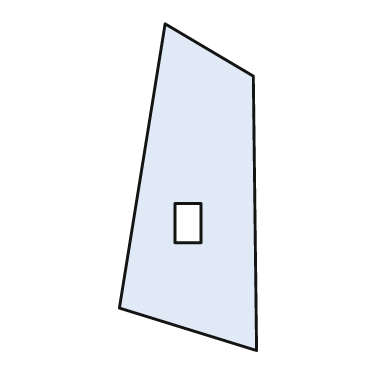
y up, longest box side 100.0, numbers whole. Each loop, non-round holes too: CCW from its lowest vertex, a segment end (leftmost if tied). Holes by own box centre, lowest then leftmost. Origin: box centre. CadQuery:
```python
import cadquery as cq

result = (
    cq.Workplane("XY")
    .moveTo(21.0, -50.0)
    .lineTo(20.0, 34.0)
    .lineTo(-7.0, 50.0)
    .lineTo(-21.0, -37.0)
    .close()
    .moveTo(-4.0, -17.0)
    .lineTo(4.0, -17.0)
    .lineTo(4.0, -5.0)
    .lineTo(-4.0, -5.0)
    .close()
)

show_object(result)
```